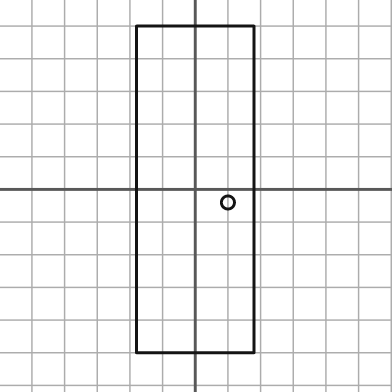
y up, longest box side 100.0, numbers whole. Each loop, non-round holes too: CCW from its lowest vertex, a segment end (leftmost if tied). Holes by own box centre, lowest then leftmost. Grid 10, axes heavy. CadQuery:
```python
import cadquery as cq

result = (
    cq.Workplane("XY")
    .moveTo(-18.0, -50.0)
    .lineTo(18.0, -50.0)
    .lineTo(18.0, 50.0)
    .lineTo(-18.0, 50.0)
    .close()
    .moveTo(10.0, -4.0)
    .circle(2.0)
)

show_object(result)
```